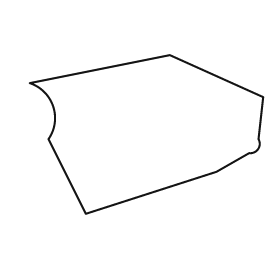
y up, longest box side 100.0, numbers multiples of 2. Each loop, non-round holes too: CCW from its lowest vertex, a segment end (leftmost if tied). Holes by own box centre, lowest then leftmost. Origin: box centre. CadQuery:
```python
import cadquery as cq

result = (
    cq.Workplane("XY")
    .moveTo(-26.0, -34.0)
    .lineTo(30.0, -16.0)
    .lineTo(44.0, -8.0)
    .threePointArc((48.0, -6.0), (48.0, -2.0))
    .lineTo(50.0, 16.0)
    .lineTo(10.0, 34.0)
    .lineTo(-50.0, 22.0)
    .threePointArc((-40.0, 12.0), (-42.0, -2.0))
    .close()
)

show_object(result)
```